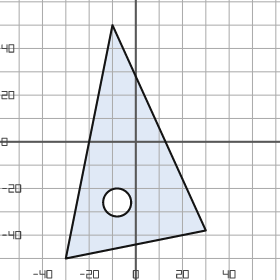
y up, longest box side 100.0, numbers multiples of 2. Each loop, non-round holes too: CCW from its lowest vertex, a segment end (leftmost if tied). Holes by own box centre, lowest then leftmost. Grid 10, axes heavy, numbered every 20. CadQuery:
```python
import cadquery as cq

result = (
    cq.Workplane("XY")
    .moveTo(-30.0, -50.0)
    .lineTo(30.0, -38.0)
    .lineTo(-10.0, 50.0)
    .close()
    .moveTo(-8.0, -26.0)
    .circle(6.0)
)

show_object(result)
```